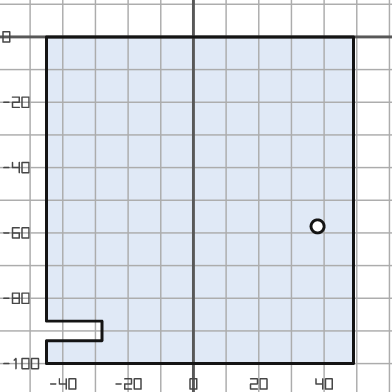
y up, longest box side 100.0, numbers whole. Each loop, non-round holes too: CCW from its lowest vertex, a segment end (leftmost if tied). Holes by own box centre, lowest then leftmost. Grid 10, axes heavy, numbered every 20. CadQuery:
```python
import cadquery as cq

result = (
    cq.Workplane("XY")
    .moveTo(-45.0, -100.0)
    .lineTo(49.0, -100.0)
    .lineTo(49.0, 0.0)
    .lineTo(-45.0, 0.0)
    .lineTo(-45.0, -87.0)
    .lineTo(-28.0, -87.0)
    .lineTo(-28.0, -93.0)
    .lineTo(-45.0, -93.0)
    .close()
    .moveTo(38.0, -58.0)
    .circle(2.0)
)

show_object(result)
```